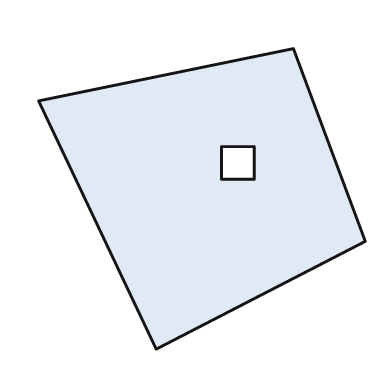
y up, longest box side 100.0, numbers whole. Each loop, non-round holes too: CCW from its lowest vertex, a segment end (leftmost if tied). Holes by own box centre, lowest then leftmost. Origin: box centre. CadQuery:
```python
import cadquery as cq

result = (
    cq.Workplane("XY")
    .moveTo(-14.0, -46.0)
    .lineTo(50.0, -13.0)
    .lineTo(28.0, 46.0)
    .lineTo(-50.0, 30.0)
    .close()
    .moveTo(6.0, 6.0)
    .lineTo(16.0, 6.0)
    .lineTo(16.0, 16.0)
    .lineTo(6.0, 16.0)
    .close()
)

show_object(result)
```